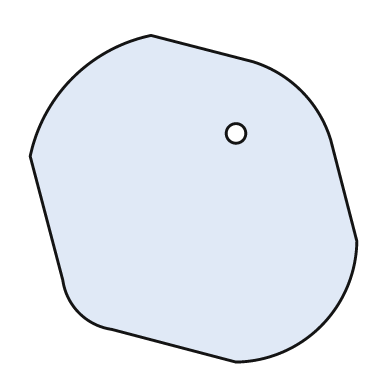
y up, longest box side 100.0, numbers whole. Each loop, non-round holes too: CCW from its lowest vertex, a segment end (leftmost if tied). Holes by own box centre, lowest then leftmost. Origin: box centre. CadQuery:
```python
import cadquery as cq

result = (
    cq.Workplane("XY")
    .moveTo(13.0, -50.0)
    .threePointArc((39.0, -39.0), (50.0, -13.0))
    .lineTo(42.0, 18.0)
    .threePointArc((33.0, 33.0), (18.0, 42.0))
    .lineTo(-13.0, 50.0)
    .threePointArc((-37.0, 37.0), (-50.0, 13.0))
    .lineTo(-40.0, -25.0)
    .threePointArc((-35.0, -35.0), (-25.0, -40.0))
    .close()
    .moveTo(13.0, 20.0)
    .circle(3.0)
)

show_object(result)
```